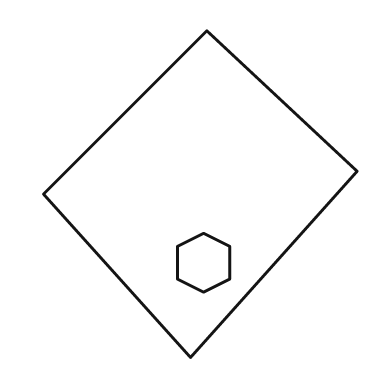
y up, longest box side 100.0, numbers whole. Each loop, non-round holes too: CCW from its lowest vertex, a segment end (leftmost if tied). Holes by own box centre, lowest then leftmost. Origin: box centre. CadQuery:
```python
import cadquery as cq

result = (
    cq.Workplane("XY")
    .moveTo(-3.0, -50.0)
    .lineTo(48.0, 7.0)
    .lineTo(2.0, 50.0)
    .lineTo(-48.0, 0.0)
    .close()
    .moveTo(1.0, -30.0)
    .lineTo(9.0, -26.0)
    .lineTo(9.0, -16.0)
    .lineTo(1.0, -12.0)
    .lineTo(-7.0, -16.0)
    .lineTo(-7.0, -26.0)
    .close()
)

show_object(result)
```